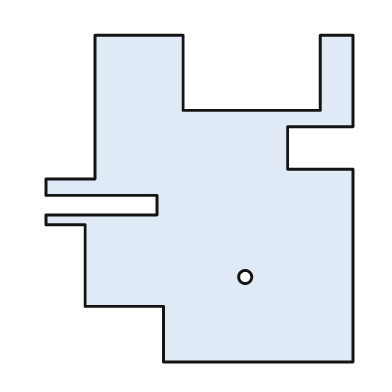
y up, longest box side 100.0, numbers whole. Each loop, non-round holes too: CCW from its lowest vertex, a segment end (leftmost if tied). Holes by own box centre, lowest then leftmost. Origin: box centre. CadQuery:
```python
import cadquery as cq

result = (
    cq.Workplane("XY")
    .moveTo(-11.0, -50.0)
    .lineTo(47.0, -50.0)
    .lineTo(47.0, 9.0)
    .lineTo(27.0, 9.0)
    .lineTo(27.0, 22.0)
    .lineTo(47.0, 22.0)
    .lineTo(47.0, 50.0)
    .lineTo(37.0, 50.0)
    .lineTo(37.0, 27.0)
    .lineTo(-5.0, 27.0)
    .lineTo(-5.0, 50.0)
    .lineTo(-32.0, 50.0)
    .lineTo(-32.0, 6.0)
    .lineTo(-47.0, 6.0)
    .lineTo(-47.0, 1.0)
    .lineTo(-13.0, 1.0)
    .lineTo(-13.0, -5.0)
    .lineTo(-47.0, -5.0)
    .lineTo(-47.0, -8.0)
    .lineTo(-35.0, -8.0)
    .lineTo(-35.0, -33.0)
    .lineTo(-11.0, -33.0)
    .close()
    .moveTo(14.0, -24.0)
    .circle(2.0)
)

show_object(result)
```